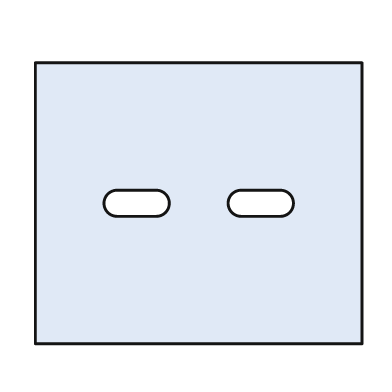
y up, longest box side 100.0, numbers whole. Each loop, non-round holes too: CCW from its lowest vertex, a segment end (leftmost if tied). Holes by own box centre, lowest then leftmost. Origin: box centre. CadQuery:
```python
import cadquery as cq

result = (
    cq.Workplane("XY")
    .moveTo(-50.0, -43.0)
    .lineTo(50.0, -43.0)
    .lineTo(50.0, 43.0)
    .lineTo(-50.0, 43.0)
    .close()
    .moveTo(-25.0, -4.0)
    .lineTo(-13.0, -4.0)
    .threePointArc((-9.0, 0.0), (-13.0, 4.0))
    .lineTo(-25.0, 4.0)
    .threePointArc((-29.0, 0.0), (-25.0, -4.0))
    .close()
    .moveTo(13.0, -4.0)
    .lineTo(25.0, -4.0)
    .threePointArc((29.0, 0.0), (25.0, 4.0))
    .lineTo(13.0, 4.0)
    .threePointArc((9.0, 0.0), (13.0, -4.0))
    .close()
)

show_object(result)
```